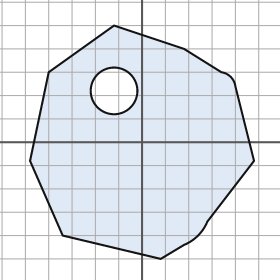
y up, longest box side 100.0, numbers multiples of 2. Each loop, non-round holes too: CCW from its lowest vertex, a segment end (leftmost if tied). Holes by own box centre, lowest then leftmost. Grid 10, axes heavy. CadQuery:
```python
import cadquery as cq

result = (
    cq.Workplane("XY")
    .moveTo(8.0, -50.0)
    .lineTo(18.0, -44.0)
    .threePointArc((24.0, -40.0), (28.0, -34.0))
    .lineTo(48.0, -8.0)
    .lineTo(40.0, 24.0)
    .threePointArc((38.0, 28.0), (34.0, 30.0))
    .lineTo(18.0, 40.0)
    .lineTo(-12.0, 50.0)
    .lineTo(-40.0, 30.0)
    .lineTo(-48.0, -8.0)
    .lineTo(-34.0, -40.0)
    .close()
    .moveTo(-12.0, 22.0)
    .circle(10.0)
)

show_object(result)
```